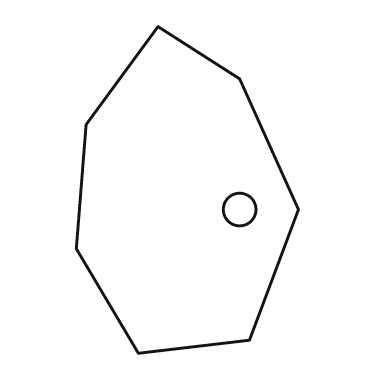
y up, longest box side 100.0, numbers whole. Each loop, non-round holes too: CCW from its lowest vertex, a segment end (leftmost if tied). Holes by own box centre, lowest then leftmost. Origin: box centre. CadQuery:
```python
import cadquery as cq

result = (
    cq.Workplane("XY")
    .moveTo(-15.0, -50.0)
    .lineTo(19.0, -46.0)
    .lineTo(34.0, -6.0)
    .lineTo(16.0, 34.0)
    .lineTo(-9.0, 50.0)
    .lineTo(-31.0, 20.0)
    .lineTo(-34.0, -18.0)
    .close()
    .moveTo(16.0, -6.0)
    .circle(5.0)
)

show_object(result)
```